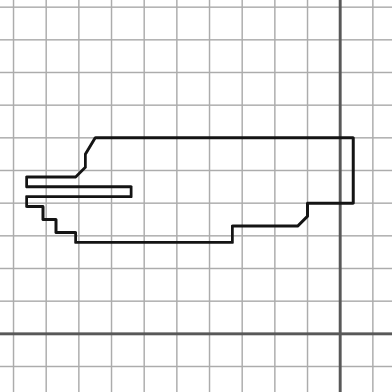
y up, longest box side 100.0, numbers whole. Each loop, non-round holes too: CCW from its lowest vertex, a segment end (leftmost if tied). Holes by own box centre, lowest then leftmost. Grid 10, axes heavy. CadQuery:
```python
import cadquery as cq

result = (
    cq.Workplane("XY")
    .moveTo(-81.0, 28.0)
    .lineTo(-33.0, 28.0)
    .lineTo(-33.0, 33.0)
    .lineTo(-13.0, 33.0)
    .lineTo(-10.0, 36.0)
    .lineTo(-10.0, 40.0)
    .lineTo(4.0, 40.0)
    .lineTo(4.0, 60.0)
    .lineTo(-75.0, 60.0)
    .lineTo(-78.0, 55.0)
    .lineTo(-78.0, 51.0)
    .lineTo(-81.0, 48.0)
    .lineTo(-96.0, 48.0)
    .lineTo(-96.0, 45.0)
    .lineTo(-64.0, 45.0)
    .lineTo(-64.0, 42.0)
    .lineTo(-96.0, 42.0)
    .lineTo(-96.0, 39.0)
    .lineTo(-91.0, 39.0)
    .lineTo(-91.0, 35.0)
    .lineTo(-87.0, 35.0)
    .lineTo(-87.0, 31.0)
    .lineTo(-81.0, 31.0)
    .close()
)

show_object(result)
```